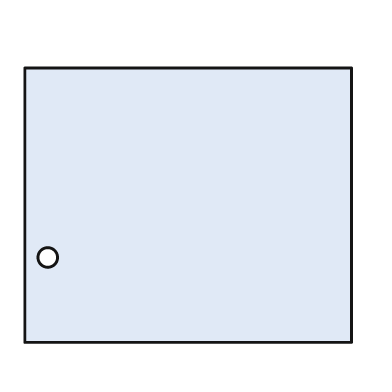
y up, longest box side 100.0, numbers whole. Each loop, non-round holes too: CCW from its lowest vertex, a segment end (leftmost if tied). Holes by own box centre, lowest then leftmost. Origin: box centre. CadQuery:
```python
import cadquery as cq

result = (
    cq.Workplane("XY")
    .moveTo(-50.0, -42.0)
    .lineTo(50.0, -42.0)
    .lineTo(50.0, 42.0)
    .lineTo(-50.0, 42.0)
    .close()
    .moveTo(-43.0, -16.0)
    .circle(3.0)
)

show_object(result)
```